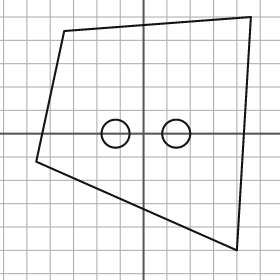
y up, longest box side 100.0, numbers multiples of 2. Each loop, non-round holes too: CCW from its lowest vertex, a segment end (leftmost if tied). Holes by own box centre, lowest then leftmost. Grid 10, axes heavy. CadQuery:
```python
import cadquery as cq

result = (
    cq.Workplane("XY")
    .moveTo(40.0, -50.0)
    .lineTo(46.0, 50.0)
    .lineTo(-34.0, 44.0)
    .lineTo(-46.0, -12.0)
    .close()
    .moveTo(-12.0, 0.0)
    .circle(6.0)
    .moveTo(14.0, 0.0)
    .circle(6.0)
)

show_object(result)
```